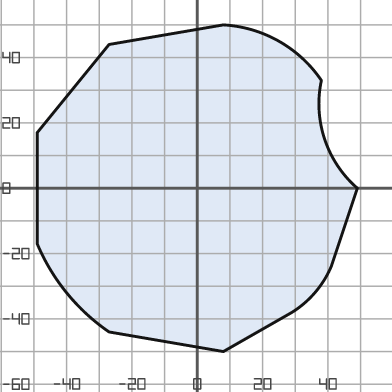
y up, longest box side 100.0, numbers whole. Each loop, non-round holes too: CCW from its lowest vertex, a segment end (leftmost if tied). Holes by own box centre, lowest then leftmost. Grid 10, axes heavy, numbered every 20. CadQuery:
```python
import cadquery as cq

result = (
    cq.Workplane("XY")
    .moveTo(8.0, -50.0)
    .lineTo(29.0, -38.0)
    .threePointArc((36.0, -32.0), (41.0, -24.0))
    .lineTo(49.0, 0.0)
    .threePointArc((39.0, 15.0), (38.0, 33.0))
    .threePointArc((25.0, 45.0), (8.0, 50.0))
    .lineTo(-27.0, 44.0)
    .lineTo(-49.0, 17.0)
    .lineTo(-49.0, -17.0)
    .threePointArc((-40.0, -32.0), (-27.0, -44.0))
    .close()
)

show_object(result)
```